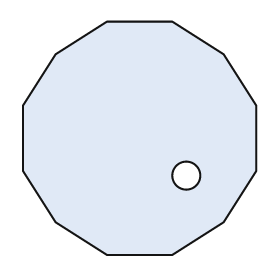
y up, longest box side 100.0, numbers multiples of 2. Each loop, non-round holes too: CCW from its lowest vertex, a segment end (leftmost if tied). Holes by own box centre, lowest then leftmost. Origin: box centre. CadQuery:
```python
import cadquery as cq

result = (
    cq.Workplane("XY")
    .moveTo(-14.0, -50.0)
    .lineTo(14.0, -50.0)
    .lineTo(36.0, -36.0)
    .lineTo(50.0, -14.0)
    .lineTo(50.0, 14.0)
    .lineTo(36.0, 36.0)
    .lineTo(14.0, 50.0)
    .lineTo(-14.0, 50.0)
    .lineTo(-36.0, 36.0)
    .lineTo(-50.0, 14.0)
    .lineTo(-50.0, -14.0)
    .lineTo(-36.0, -36.0)
    .close()
    .moveTo(20.0, -16.0)
    .circle(6.0)
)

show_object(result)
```